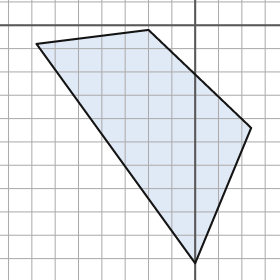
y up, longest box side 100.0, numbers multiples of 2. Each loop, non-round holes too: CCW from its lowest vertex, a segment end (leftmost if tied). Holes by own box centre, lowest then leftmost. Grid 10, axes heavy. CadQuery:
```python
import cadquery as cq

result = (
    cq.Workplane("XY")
    .moveTo(0.0, -102.0)
    .lineTo(24.0, -44.0)
    .lineTo(-20.0, -2.0)
    .lineTo(-68.0, -8.0)
    .close()
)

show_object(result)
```